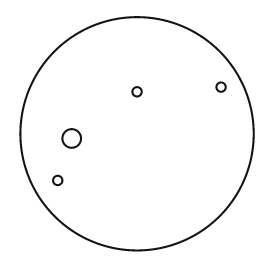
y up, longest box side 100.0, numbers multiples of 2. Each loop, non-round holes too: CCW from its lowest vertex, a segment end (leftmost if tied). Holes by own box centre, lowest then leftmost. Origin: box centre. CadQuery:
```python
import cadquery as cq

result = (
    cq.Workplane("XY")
    .moveTo(0.0, 0.0)
    .circle(50.0)
    .moveTo(-34.0, -20.0)
    .circle(2.0)
    .moveTo(-28.0, -2.0)
    .circle(4.0)
    .moveTo(0.0, 18.0)
    .circle(2.0)
    .moveTo(36.0, 20.0)
    .circle(2.0)
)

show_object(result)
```